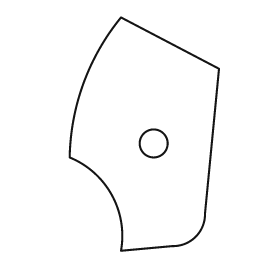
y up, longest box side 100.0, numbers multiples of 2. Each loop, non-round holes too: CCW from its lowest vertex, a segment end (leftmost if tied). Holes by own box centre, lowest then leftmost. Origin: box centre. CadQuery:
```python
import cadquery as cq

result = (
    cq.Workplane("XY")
    .moveTo(-10.0, -50.0)
    .lineTo(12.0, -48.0)
    .threePointArc((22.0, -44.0), (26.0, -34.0))
    .lineTo(32.0, 28.0)
    .lineTo(-10.0, 50.0)
    .threePointArc((-26.0, 22.0), (-32.0, -10.0))
    .threePointArc((-14.0, -26.0), (-10.0, -50.0))
    .close()
    .moveTo(4.0, -4.0)
    .circle(6.0)
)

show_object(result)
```